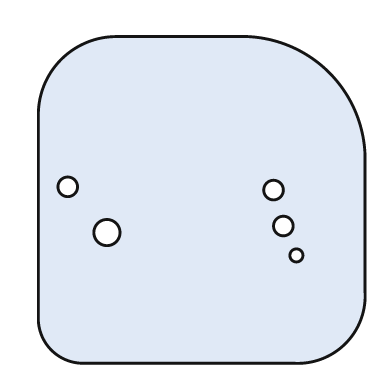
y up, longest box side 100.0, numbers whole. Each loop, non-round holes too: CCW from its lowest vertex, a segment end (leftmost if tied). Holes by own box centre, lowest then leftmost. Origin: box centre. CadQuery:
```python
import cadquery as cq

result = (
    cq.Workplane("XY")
    .moveTo(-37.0, -50.0)
    .lineTo(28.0, -50.0)
    .threePointArc((44.0, -44.0), (50.0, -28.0))
    .lineTo(50.0, 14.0)
    .threePointArc((39.0, 39.0), (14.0, 50.0))
    .lineTo(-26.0, 50.0)
    .threePointArc((-43.0, 43.0), (-50.0, 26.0))
    .lineTo(-50.0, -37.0)
    .threePointArc((-46.0, -46.0), (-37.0, -50.0))
    .close()
    .moveTo(29.0, -17.0)
    .circle(2.0)
    .moveTo(-29.0, -10.0)
    .circle(4.0)
    .moveTo(25.0, -8.0)
    .circle(3.0)
    .moveTo(22.0, 3.0)
    .circle(3.0)
    .moveTo(-41.0, 4.0)
    .circle(3.0)
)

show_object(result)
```